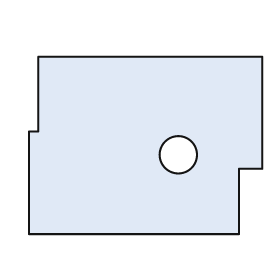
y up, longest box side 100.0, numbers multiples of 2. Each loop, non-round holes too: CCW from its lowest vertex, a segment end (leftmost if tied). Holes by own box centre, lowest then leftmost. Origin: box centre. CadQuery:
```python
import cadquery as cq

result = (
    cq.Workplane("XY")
    .moveTo(-50.0, -38.0)
    .lineTo(40.0, -38.0)
    .lineTo(40.0, -10.0)
    .lineTo(50.0, -10.0)
    .lineTo(50.0, 38.0)
    .lineTo(-46.0, 38.0)
    .lineTo(-46.0, 6.0)
    .lineTo(-50.0, 6.0)
    .close()
    .moveTo(14.0, -4.0)
    .circle(8.0)
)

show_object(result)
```